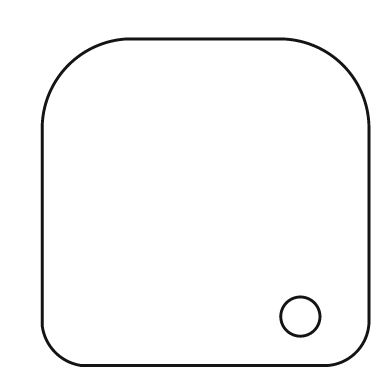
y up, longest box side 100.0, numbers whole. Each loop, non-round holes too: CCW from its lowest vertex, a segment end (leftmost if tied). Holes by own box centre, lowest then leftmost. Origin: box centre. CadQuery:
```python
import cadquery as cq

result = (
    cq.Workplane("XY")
    .moveTo(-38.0, -50.0)
    .lineTo(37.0, -50.0)
    .threePointArc((46.0, -46.0), (50.0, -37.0))
    .lineTo(50.0, 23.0)
    .threePointArc((42.0, 42.0), (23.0, 50.0))
    .lineTo(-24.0, 50.0)
    .threePointArc((-42.0, 42.0), (-50.0, 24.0))
    .lineTo(-50.0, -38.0)
    .threePointArc((-46.0, -46.0), (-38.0, -50.0))
    .close()
    .moveTo(29.0, -35.0)
    .circle(6.0)
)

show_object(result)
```